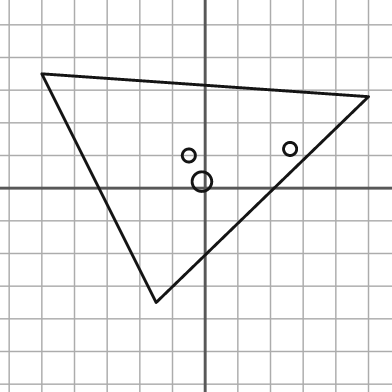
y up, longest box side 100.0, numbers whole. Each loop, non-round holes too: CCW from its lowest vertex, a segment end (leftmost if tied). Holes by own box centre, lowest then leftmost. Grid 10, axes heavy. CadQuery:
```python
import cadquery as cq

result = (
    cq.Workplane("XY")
    .moveTo(-15.0, -35.0)
    .lineTo(50.0, 28.0)
    .lineTo(-50.0, 35.0)
    .close()
    .moveTo(-1.0, 2.0)
    .circle(3.0)
    .moveTo(-5.0, 10.0)
    .circle(2.0)
    .moveTo(26.0, 12.0)
    .circle(2.0)
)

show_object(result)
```